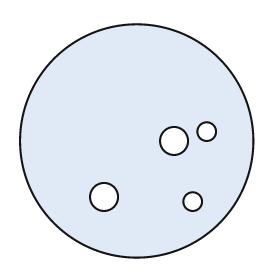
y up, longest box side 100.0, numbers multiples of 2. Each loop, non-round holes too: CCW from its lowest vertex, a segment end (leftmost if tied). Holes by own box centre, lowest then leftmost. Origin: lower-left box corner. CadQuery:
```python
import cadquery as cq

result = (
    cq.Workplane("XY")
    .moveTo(50.0, 50.0)
    .circle(50.0)
    .moveTo(74.0, 24.0)
    .circle(4.0)
    .moveTo(36.0, 26.0)
    .circle(6.0)
    .moveTo(66.0, 50.0)
    .circle(6.0)
    .moveTo(80.0, 54.0)
    .circle(4.0)
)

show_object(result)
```